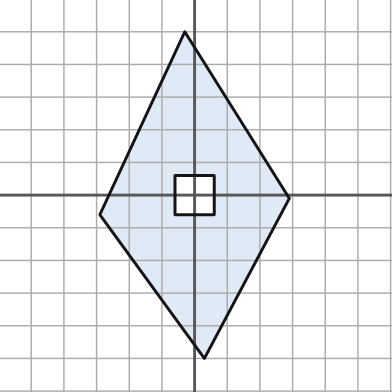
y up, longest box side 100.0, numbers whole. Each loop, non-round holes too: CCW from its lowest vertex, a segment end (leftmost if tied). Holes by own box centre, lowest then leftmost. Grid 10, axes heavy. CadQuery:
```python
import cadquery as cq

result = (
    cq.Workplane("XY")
    .moveTo(3.0, -50.0)
    .lineTo(29.0, -1.0)
    .lineTo(-3.0, 50.0)
    .lineTo(-29.0, -6.0)
    .close()
    .moveTo(-6.0, -6.0)
    .lineTo(6.0, -6.0)
    .lineTo(6.0, 6.0)
    .lineTo(-6.0, 6.0)
    .close()
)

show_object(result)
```